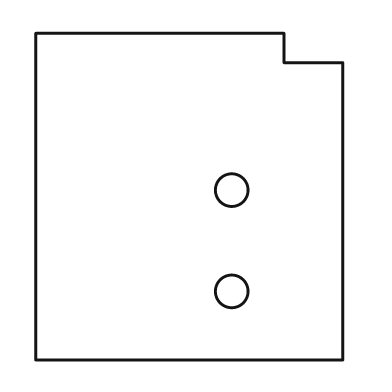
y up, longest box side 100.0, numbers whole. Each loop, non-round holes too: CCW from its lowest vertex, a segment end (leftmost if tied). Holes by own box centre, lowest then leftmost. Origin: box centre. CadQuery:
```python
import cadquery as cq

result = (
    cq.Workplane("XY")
    .moveTo(-47.0, -50.0)
    .lineTo(47.0, -50.0)
    .lineTo(47.0, 41.0)
    .lineTo(29.0, 41.0)
    .lineTo(29.0, 50.0)
    .lineTo(-47.0, 50.0)
    .close()
    .moveTo(13.0, -29.0)
    .circle(5.0)
    .moveTo(13.0, 2.0)
    .circle(5.0)
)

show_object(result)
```